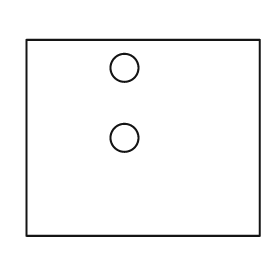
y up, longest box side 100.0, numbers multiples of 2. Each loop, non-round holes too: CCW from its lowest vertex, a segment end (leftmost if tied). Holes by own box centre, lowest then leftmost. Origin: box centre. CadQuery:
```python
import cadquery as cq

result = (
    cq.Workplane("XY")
    .moveTo(-50.0, -42.0)
    .lineTo(50.0, -42.0)
    .lineTo(50.0, 42.0)
    .lineTo(-50.0, 42.0)
    .close()
    .moveTo(-8.0, 0.0)
    .circle(6.0)
    .moveTo(-8.0, 30.0)
    .circle(6.0)
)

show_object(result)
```